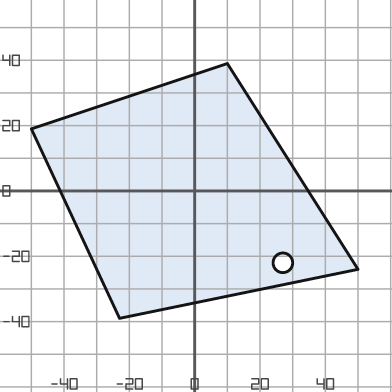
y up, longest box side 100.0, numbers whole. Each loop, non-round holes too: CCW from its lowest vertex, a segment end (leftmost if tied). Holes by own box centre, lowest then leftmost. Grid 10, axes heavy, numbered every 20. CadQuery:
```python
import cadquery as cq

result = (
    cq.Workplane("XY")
    .moveTo(-23.0, -39.0)
    .lineTo(50.0, -24.0)
    .lineTo(10.0, 39.0)
    .lineTo(-50.0, 19.0)
    .close()
    .moveTo(27.0, -22.0)
    .circle(3.0)
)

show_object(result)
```